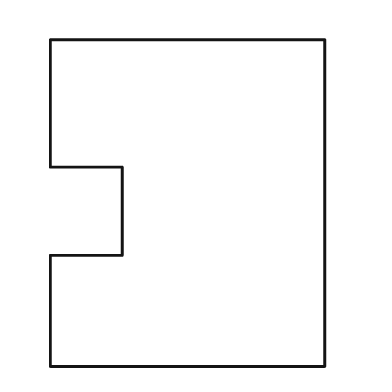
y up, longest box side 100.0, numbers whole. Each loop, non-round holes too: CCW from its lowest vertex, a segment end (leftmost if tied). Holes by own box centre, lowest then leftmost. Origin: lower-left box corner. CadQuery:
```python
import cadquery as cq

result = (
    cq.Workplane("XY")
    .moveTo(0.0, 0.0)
    .lineTo(84.0, 0.0)
    .lineTo(84.0, 100.0)
    .lineTo(0.0, 100.0)
    .lineTo(0.0, 61.0)
    .lineTo(22.0, 61.0)
    .lineTo(22.0, 34.0)
    .lineTo(0.0, 34.0)
    .close()
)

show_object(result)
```